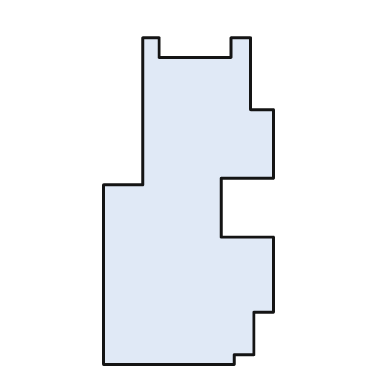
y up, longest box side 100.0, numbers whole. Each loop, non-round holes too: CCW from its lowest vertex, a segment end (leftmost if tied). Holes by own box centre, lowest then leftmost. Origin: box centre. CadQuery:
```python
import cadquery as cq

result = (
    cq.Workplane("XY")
    .moveTo(-26.0, -50.0)
    .lineTo(14.0, -50.0)
    .lineTo(14.0, -47.0)
    .lineTo(20.0, -47.0)
    .lineTo(20.0, -34.0)
    .lineTo(26.0, -34.0)
    .lineTo(26.0, -11.0)
    .lineTo(10.0, -11.0)
    .lineTo(10.0, 7.0)
    .lineTo(26.0, 7.0)
    .lineTo(26.0, 28.0)
    .lineTo(19.0, 28.0)
    .lineTo(19.0, 50.0)
    .lineTo(13.0, 50.0)
    .lineTo(13.0, 44.0)
    .lineTo(-9.0, 44.0)
    .lineTo(-9.0, 50.0)
    .lineTo(-14.0, 50.0)
    .lineTo(-14.0, 5.0)
    .lineTo(-26.0, 5.0)
    .close()
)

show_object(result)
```